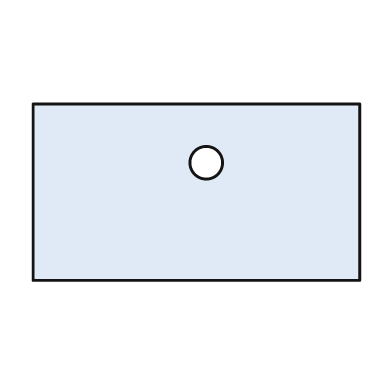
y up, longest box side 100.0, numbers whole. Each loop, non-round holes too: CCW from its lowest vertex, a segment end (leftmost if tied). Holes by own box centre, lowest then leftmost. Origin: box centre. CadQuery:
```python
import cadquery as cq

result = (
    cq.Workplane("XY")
    .moveTo(-50.0, -27.0)
    .lineTo(50.0, -27.0)
    .lineTo(50.0, 27.0)
    .lineTo(-50.0, 27.0)
    .close()
    .moveTo(3.0, 9.0)
    .circle(5.0)
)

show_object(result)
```